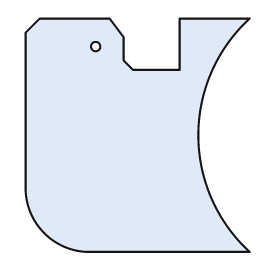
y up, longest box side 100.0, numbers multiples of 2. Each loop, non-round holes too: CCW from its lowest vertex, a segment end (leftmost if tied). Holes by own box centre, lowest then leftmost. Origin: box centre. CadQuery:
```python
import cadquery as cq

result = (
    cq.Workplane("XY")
    .moveTo(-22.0, -50.0)
    .lineTo(48.0, -50.0)
    .threePointArc((26.0, 0.0), (48.0, 50.0))
    .lineTo(18.0, 50.0)
    .lineTo(18.0, 28.0)
    .lineTo(-2.0, 28.0)
    .lineTo(-6.0, 32.0)
    .lineTo(-6.0, 42.0)
    .lineTo(-12.0, 50.0)
    .lineTo(-42.0, 50.0)
    .lineTo(-48.0, 44.0)
    .lineTo(-48.0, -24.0)
    .threePointArc((-40.0, -42.0), (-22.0, -50.0))
    .close()
    .moveTo(-18.0, 38.0)
    .circle(2.0)
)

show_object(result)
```